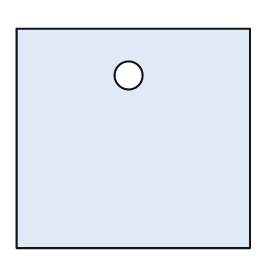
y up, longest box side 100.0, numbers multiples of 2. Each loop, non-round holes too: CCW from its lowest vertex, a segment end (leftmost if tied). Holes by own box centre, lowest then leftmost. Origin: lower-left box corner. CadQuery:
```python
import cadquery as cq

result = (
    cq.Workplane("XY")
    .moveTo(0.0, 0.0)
    .lineTo(100.0, 0.0)
    .lineTo(100.0, 94.0)
    .lineTo(0.0, 94.0)
    .close()
    .moveTo(48.0, 74.0)
    .circle(6.0)
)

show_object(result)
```